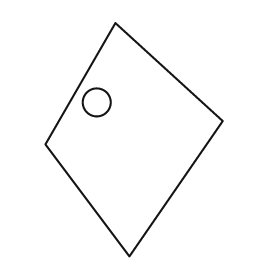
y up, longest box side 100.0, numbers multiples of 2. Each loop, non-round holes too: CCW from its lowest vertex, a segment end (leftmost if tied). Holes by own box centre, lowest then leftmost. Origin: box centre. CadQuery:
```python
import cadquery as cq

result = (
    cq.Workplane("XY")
    .moveTo(-2.0, -50.0)
    .lineTo(38.0, 8.0)
    .lineTo(-8.0, 50.0)
    .lineTo(-38.0, -2.0)
    .close()
    .moveTo(-16.0, 16.0)
    .circle(6.0)
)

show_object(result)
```